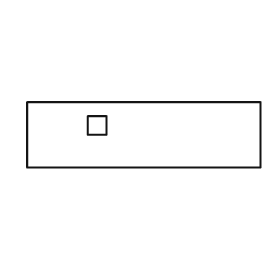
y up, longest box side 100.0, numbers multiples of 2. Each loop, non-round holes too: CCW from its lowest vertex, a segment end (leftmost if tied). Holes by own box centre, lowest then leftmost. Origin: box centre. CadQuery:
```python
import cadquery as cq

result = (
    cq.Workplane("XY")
    .moveTo(-50.0, -14.0)
    .lineTo(50.0, -14.0)
    .lineTo(50.0, 14.0)
    .lineTo(-50.0, 14.0)
    .close()
    .moveTo(-24.0, 0.0)
    .lineTo(-16.0, 0.0)
    .lineTo(-16.0, 8.0)
    .lineTo(-24.0, 8.0)
    .close()
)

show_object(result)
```